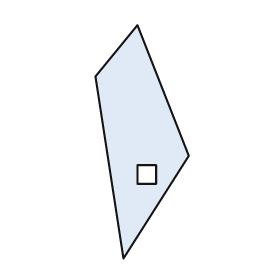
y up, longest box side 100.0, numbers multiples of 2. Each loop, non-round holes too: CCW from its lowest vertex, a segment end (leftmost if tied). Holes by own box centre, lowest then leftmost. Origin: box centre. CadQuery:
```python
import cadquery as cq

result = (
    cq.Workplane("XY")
    .moveTo(-8.0, -50.0)
    .lineTo(20.0, -6.0)
    .lineTo(-2.0, 50.0)
    .lineTo(-20.0, 28.0)
    .close()
    .moveTo(-2.0, -18.0)
    .lineTo(6.0, -18.0)
    .lineTo(6.0, -10.0)
    .lineTo(-2.0, -10.0)
    .close()
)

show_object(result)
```